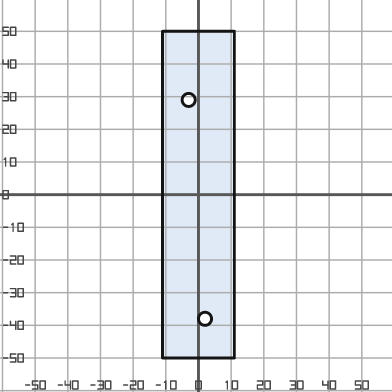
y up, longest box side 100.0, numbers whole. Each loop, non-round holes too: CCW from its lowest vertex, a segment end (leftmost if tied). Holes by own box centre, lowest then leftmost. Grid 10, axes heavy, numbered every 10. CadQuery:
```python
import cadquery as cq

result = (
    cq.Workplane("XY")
    .moveTo(-11.0, -50.0)
    .lineTo(11.0, -50.0)
    .lineTo(11.0, 50.0)
    .lineTo(-11.0, 50.0)
    .close()
    .moveTo(2.0, -38.0)
    .circle(2.0)
    .moveTo(-3.0, 29.0)
    .circle(2.0)
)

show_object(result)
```